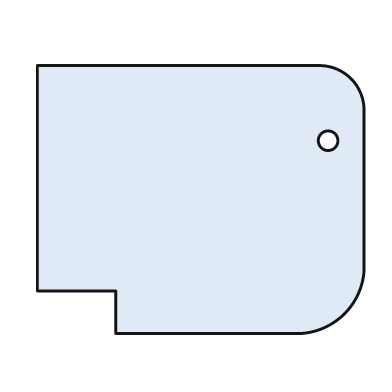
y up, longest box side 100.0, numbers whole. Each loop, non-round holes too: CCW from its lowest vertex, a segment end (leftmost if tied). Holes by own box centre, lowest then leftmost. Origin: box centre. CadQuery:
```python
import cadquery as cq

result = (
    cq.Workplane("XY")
    .moveTo(-26.0, -41.0)
    .lineTo(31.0, -41.0)
    .threePointArc((44.0, -35.0), (50.0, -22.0))
    .lineTo(50.0, 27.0)
    .threePointArc((46.0, 37.0), (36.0, 41.0))
    .lineTo(-50.0, 41.0)
    .lineTo(-50.0, -28.0)
    .lineTo(-26.0, -28.0)
    .close()
    .moveTo(39.0, 18.0)
    .circle(3.0)
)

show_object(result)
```